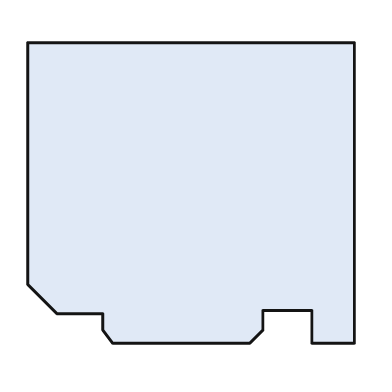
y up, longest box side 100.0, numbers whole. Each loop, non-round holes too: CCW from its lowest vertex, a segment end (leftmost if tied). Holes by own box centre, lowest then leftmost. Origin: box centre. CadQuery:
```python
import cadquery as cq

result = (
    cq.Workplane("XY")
    .moveTo(-24.0, -46.0)
    .lineTo(18.0, -46.0)
    .lineTo(22.0, -42.0)
    .lineTo(22.0, -36.0)
    .lineTo(37.0, -36.0)
    .lineTo(37.0, -46.0)
    .lineTo(50.0, -46.0)
    .lineTo(50.0, 46.0)
    .lineTo(-50.0, 46.0)
    .lineTo(-50.0, -28.0)
    .lineTo(-41.0, -37.0)
    .lineTo(-27.0, -37.0)
    .lineTo(-27.0, -42.0)
    .close()
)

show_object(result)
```